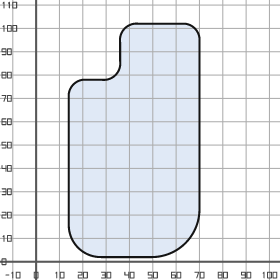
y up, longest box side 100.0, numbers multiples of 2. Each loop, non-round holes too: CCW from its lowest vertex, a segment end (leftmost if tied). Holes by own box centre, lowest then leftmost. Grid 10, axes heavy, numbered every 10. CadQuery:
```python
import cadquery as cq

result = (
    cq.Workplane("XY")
    .moveTo(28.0, 2.0)
    .lineTo(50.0, 2.0)
    .threePointArc((64.0, 8.0), (70.0, 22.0))
    .lineTo(70.0, 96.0)
    .threePointArc((68.0, 100.0), (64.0, 102.0))
    .lineTo(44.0, 102.0)
    .threePointArc((38.0, 100.0), (36.0, 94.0))
    .lineTo(36.0, 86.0)
    .threePointArc((34.0, 80.0), (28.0, 78.0))
    .lineTo(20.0, 78.0)
    .threePointArc((16.0, 76.0), (14.0, 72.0))
    .lineTo(14.0, 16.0)
    .threePointArc((18.0, 6.0), (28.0, 2.0))
    .close()
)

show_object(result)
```